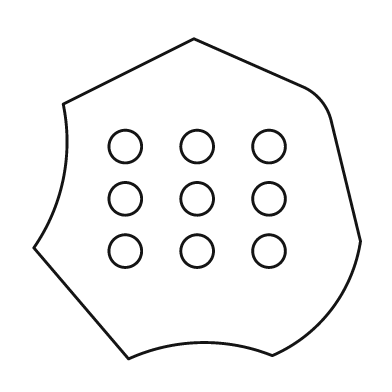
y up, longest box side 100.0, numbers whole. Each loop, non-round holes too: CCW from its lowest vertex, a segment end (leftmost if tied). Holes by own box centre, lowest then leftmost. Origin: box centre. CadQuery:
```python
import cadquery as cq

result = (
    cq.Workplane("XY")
    .moveTo(-21.0, -49.0)
    .threePointArc((1.0, -44.0), (23.0, -48.0))
    .threePointArc((41.0, -34.0), (50.0, -13.0))
    .lineTo(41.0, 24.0)
    .threePointArc((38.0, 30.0), (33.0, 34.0))
    .lineTo(-1.0, 49.0)
    .lineTo(-41.0, 29.0)
    .threePointArc((-41.0, 6.0), (-50.0, -15.0))
    .close()
    .moveTo(-22.0, -16.0)
    .circle(5.0)
    .moveTo(0.0, -16.0)
    .circle(5.0)
    .moveTo(22.0, -16.0)
    .circle(5.0)
    .moveTo(-22.0, 0.0)
    .circle(5.0)
    .moveTo(0.0, 0.0)
    .circle(5.0)
    .moveTo(22.0, 0.0)
    .circle(5.0)
    .moveTo(-22.0, 16.0)
    .circle(5.0)
    .moveTo(0.0, 16.0)
    .circle(5.0)
    .moveTo(22.0, 16.0)
    .circle(5.0)
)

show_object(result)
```